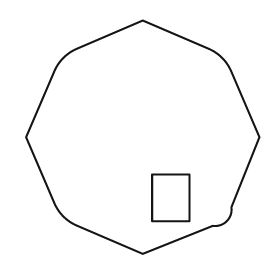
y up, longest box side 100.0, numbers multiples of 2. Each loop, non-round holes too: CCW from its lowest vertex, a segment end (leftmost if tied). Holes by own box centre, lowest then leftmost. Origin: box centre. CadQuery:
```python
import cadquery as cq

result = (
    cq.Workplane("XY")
    .moveTo(0.0, -50.0)
    .lineTo(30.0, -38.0)
    .threePointArc((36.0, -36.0), (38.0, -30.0))
    .lineTo(50.0, 0.0)
    .lineTo(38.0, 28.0)
    .threePointArc((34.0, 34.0), (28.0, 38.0))
    .lineTo(0.0, 50.0)
    .lineTo(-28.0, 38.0)
    .threePointArc((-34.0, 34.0), (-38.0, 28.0))
    .lineTo(-50.0, 0.0)
    .lineTo(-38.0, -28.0)
    .threePointArc((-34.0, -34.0), (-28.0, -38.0))
    .close()
    .moveTo(4.0, -36.0)
    .lineTo(20.0, -36.0)
    .lineTo(20.0, -16.0)
    .lineTo(4.0, -16.0)
    .close()
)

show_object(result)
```